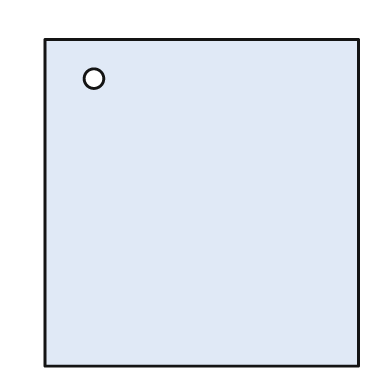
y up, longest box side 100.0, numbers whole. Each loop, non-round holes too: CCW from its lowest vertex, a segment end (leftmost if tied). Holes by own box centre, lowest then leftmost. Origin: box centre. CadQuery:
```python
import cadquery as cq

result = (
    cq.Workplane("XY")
    .moveTo(-48.0, -50.0)
    .lineTo(48.0, -50.0)
    .lineTo(48.0, 50.0)
    .lineTo(-48.0, 50.0)
    .close()
    .moveTo(-33.0, 38.0)
    .circle(3.0)
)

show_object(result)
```